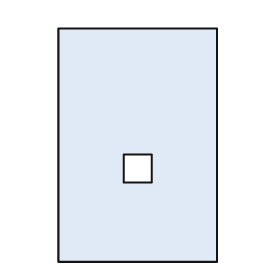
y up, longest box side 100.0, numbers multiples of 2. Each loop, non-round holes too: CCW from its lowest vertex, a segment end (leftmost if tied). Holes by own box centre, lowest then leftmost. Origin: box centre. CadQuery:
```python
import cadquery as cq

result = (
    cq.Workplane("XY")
    .moveTo(-34.0, -50.0)
    .lineTo(34.0, -50.0)
    .lineTo(34.0, 50.0)
    .lineTo(-34.0, 50.0)
    .close()
    .moveTo(-6.0, -16.0)
    .lineTo(6.0, -16.0)
    .lineTo(6.0, -4.0)
    .lineTo(-6.0, -4.0)
    .close()
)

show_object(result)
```